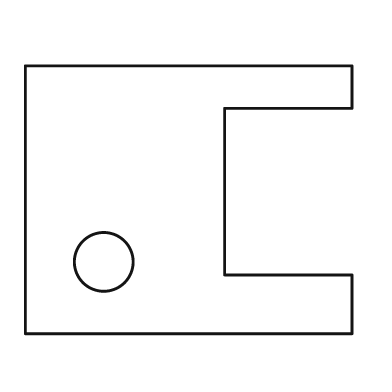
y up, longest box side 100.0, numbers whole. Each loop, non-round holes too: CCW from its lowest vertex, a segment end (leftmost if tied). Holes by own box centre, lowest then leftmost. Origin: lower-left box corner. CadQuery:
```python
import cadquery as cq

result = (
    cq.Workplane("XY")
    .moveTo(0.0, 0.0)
    .lineTo(100.0, 0.0)
    .lineTo(100.0, 18.0)
    .lineTo(61.0, 18.0)
    .lineTo(61.0, 69.0)
    .lineTo(100.0, 69.0)
    .lineTo(100.0, 82.0)
    .lineTo(0.0, 82.0)
    .close()
    .moveTo(24.0, 22.0)
    .circle(9.0)
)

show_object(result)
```